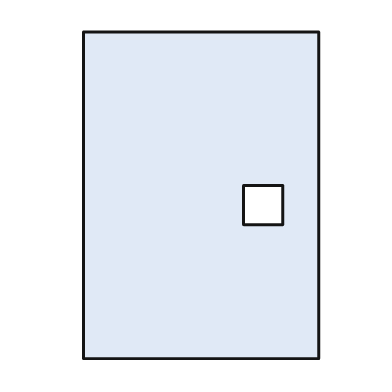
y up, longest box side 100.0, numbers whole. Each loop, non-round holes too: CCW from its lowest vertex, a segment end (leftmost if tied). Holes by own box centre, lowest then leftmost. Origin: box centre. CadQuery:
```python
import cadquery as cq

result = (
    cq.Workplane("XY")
    .moveTo(-36.0, -50.0)
    .lineTo(36.0, -50.0)
    .lineTo(36.0, 50.0)
    .lineTo(-36.0, 50.0)
    .close()
    .moveTo(13.0, -9.0)
    .lineTo(25.0, -9.0)
    .lineTo(25.0, 3.0)
    .lineTo(13.0, 3.0)
    .close()
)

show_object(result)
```